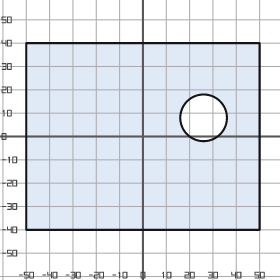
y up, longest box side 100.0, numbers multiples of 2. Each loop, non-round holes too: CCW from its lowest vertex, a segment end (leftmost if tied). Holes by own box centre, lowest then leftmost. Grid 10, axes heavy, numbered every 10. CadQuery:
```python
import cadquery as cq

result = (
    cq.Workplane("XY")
    .moveTo(-50.0, -40.0)
    .lineTo(50.0, -40.0)
    .lineTo(50.0, 40.0)
    .lineTo(-50.0, 40.0)
    .close()
    .moveTo(26.0, 8.0)
    .circle(10.0)
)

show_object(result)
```